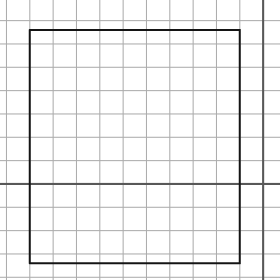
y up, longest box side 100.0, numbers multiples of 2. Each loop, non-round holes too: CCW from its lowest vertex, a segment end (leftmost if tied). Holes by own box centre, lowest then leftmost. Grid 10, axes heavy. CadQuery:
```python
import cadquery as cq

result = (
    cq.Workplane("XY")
    .moveTo(-100.0, -34.0)
    .lineTo(-10.0, -34.0)
    .lineTo(-10.0, 66.0)
    .lineTo(-100.0, 66.0)
    .close()
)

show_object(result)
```